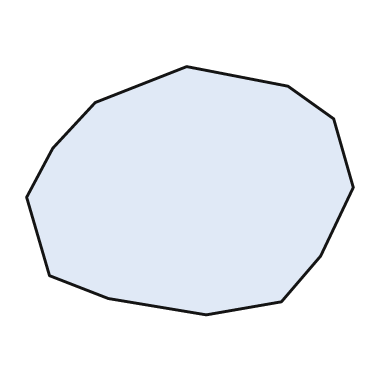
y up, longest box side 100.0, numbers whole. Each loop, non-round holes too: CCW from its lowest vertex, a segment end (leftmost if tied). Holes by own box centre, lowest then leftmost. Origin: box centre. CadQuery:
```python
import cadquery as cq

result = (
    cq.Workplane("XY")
    .moveTo(5.0, -38.0)
    .lineTo(28.0, -34.0)
    .lineTo(40.0, -20.0)
    .lineTo(50.0, 1.0)
    .lineTo(44.0, 22.0)
    .lineTo(30.0, 32.0)
    .lineTo(-1.0, 38.0)
    .lineTo(-29.0, 27.0)
    .lineTo(-42.0, 13.0)
    .lineTo(-50.0, -2.0)
    .lineTo(-43.0, -26.0)
    .lineTo(-25.0, -33.0)
    .close()
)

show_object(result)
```